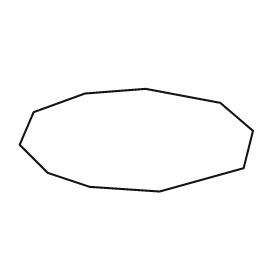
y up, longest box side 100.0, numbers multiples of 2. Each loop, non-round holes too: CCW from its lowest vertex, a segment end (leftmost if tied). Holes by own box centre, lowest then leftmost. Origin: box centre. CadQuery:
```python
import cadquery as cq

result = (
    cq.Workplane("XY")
    .moveTo(10.0, -22.0)
    .lineTo(46.0, -12.0)
    .lineTo(50.0, 4.0)
    .lineTo(36.0, 16.0)
    .lineTo(4.0, 22.0)
    .lineTo(-22.0, 20.0)
    .lineTo(-44.0, 12.0)
    .lineTo(-50.0, -2.0)
    .lineTo(-38.0, -14.0)
    .lineTo(-20.0, -20.0)
    .close()
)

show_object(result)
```